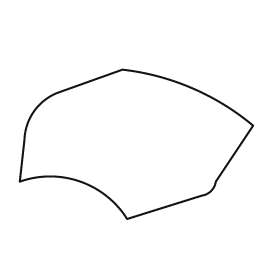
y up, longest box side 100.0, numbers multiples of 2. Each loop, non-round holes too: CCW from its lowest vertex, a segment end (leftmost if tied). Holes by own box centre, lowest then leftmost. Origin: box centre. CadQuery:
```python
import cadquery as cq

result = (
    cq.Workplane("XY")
    .moveTo(-4.0, -32.0)
    .lineTo(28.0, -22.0)
    .threePointArc((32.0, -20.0), (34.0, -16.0))
    .lineTo(50.0, 8.0)
    .threePointArc((24.0, 24.0), (-6.0, 32.0))
    .lineTo(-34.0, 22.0)
    .threePointArc((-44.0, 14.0), (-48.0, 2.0))
    .lineTo(-50.0, -16.0)
    .threePointArc((-24.0, -16.0), (-4.0, -32.0))
    .close()
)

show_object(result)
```